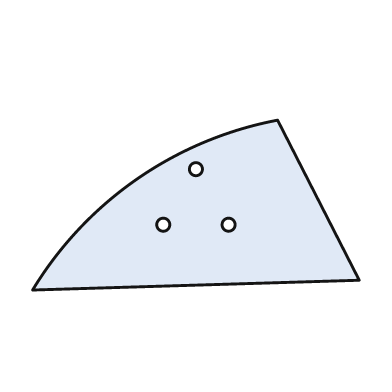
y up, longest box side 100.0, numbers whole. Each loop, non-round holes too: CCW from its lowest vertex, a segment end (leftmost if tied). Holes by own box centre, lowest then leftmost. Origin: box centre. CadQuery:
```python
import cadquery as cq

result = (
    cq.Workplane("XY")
    .moveTo(-50.0, -26.0)
    .lineTo(50.0, -23.0)
    .lineTo(25.0, 26.0)
    .threePointArc((-18.0, 8.0), (-50.0, -26.0))
    .close()
    .moveTo(-10.0, -6.0)
    .circle(2.0)
    .moveTo(10.0, -6.0)
    .circle(2.0)
    .moveTo(0.0, 11.0)
    .circle(2.0)
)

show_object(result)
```